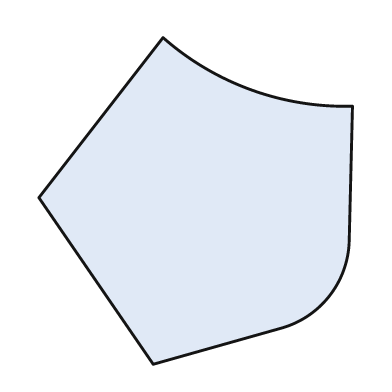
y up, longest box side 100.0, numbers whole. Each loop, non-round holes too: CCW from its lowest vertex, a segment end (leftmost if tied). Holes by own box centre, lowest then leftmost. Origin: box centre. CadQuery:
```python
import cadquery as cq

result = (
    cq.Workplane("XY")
    .moveTo(-13.0, -50.0)
    .lineTo(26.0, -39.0)
    .threePointArc((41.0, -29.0), (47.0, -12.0))
    .lineTo(48.0, 29.0)
    .threePointArc((17.0, 34.0), (-10.0, 50.0))
    .lineTo(-48.0, 1.0)
    .close()
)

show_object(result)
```